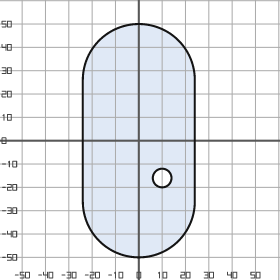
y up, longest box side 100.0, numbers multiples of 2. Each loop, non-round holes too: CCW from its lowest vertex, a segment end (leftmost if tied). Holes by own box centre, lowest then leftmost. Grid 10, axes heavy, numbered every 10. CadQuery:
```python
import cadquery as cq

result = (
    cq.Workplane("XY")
    .moveTo(-24.0, -26.0)
    .threePointArc((0.0, -50.0), (24.0, -26.0))
    .lineTo(24.0, 26.0)
    .threePointArc((0.0, 50.0), (-24.0, 26.0))
    .close()
    .moveTo(10.0, -16.0)
    .circle(4.0)
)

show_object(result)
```